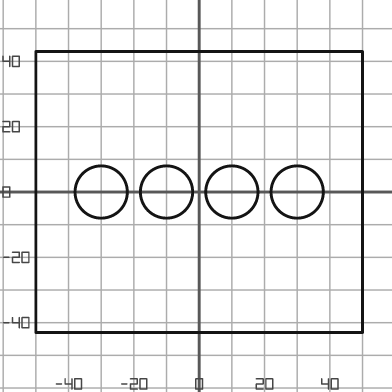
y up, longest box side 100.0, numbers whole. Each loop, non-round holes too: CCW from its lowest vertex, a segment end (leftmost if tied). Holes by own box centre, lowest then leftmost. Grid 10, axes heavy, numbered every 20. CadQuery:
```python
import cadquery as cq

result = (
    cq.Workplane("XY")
    .moveTo(-50.0, -43.0)
    .lineTo(50.0, -43.0)
    .lineTo(50.0, 43.0)
    .lineTo(-50.0, 43.0)
    .close()
    .moveTo(-30.0, 0.0)
    .circle(8.0)
    .moveTo(-10.0, 0.0)
    .circle(8.0)
    .moveTo(10.0, 0.0)
    .circle(8.0)
    .moveTo(30.0, 0.0)
    .circle(8.0)
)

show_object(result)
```